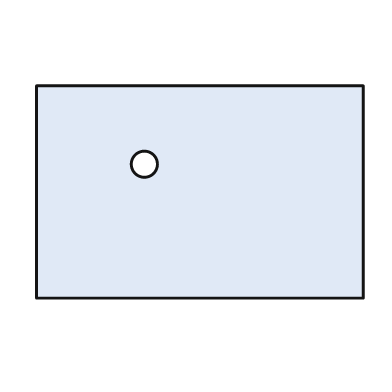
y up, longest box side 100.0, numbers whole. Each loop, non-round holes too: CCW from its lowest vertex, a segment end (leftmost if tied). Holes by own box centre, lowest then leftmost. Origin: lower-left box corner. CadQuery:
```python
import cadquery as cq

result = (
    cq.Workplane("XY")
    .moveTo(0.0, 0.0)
    .lineTo(100.0, 0.0)
    .lineTo(100.0, 65.0)
    .lineTo(0.0, 65.0)
    .close()
    .moveTo(33.0, 41.0)
    .circle(4.0)
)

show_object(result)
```